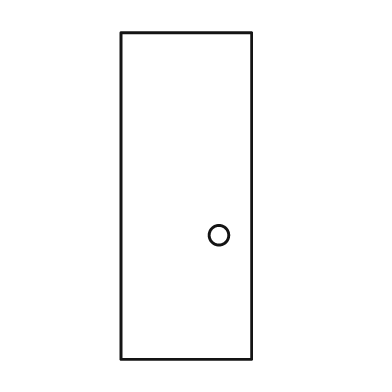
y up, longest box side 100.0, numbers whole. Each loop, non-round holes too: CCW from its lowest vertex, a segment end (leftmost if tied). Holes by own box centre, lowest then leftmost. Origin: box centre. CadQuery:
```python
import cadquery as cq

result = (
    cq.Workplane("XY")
    .moveTo(-20.0, -50.0)
    .lineTo(20.0, -50.0)
    .lineTo(20.0, 50.0)
    .lineTo(-20.0, 50.0)
    .close()
    .moveTo(10.0, -12.0)
    .circle(3.0)
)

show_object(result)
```